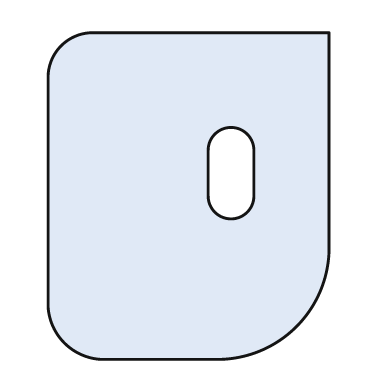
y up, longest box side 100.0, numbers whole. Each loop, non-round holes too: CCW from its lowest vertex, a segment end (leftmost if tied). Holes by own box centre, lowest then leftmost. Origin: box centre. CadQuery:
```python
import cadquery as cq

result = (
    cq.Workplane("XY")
    .moveTo(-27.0, -50.0)
    .lineTo(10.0, -50.0)
    .threePointArc((33.0, -40.0), (43.0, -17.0))
    .lineTo(43.0, 50.0)
    .lineTo(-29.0, 50.0)
    .threePointArc((-39.0, 46.0), (-43.0, 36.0))
    .lineTo(-43.0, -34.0)
    .threePointArc((-38.0, -45.0), (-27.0, -50.0))
    .close()
    .moveTo(6.0, 0.0)
    .threePointArc((13.0, -7.0), (20.0, 0.0))
    .lineTo(20.0, 14.0)
    .threePointArc((13.0, 21.0), (6.0, 14.0))
    .close()
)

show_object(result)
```